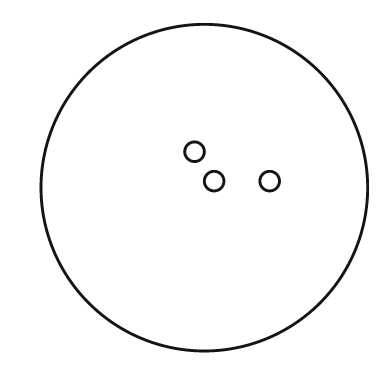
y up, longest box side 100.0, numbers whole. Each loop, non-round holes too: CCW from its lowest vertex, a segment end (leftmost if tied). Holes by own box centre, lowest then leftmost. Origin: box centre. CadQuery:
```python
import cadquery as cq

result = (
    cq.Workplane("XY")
    .moveTo(0.0, 0.0)
    .circle(50.0)
    .moveTo(3.0, 2.0)
    .circle(3.0)
    .moveTo(20.0, 2.0)
    .circle(3.0)
    .moveTo(-3.0, 11.0)
    .circle(3.0)
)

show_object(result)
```